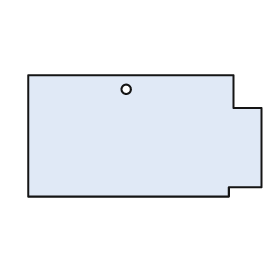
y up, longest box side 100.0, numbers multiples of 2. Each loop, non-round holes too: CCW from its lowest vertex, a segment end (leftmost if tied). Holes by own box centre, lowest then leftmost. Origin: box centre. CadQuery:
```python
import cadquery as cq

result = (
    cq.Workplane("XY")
    .moveTo(-50.0, -26.0)
    .lineTo(36.0, -26.0)
    .lineTo(36.0, -22.0)
    .lineTo(50.0, -22.0)
    .lineTo(50.0, 12.0)
    .lineTo(38.0, 12.0)
    .lineTo(38.0, 26.0)
    .lineTo(-50.0, 26.0)
    .close()
    .moveTo(-8.0, 20.0)
    .circle(2.0)
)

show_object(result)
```